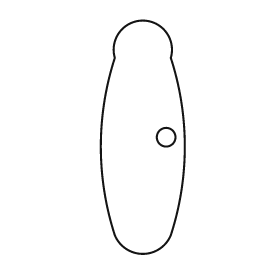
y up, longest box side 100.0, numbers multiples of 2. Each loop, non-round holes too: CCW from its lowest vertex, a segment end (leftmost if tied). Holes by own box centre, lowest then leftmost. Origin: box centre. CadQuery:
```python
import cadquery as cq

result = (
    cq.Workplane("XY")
    .moveTo(-12.0, -42.0)
    .threePointArc((0.0, -50.0), (12.0, -42.0))
    .threePointArc((18.0, -4.0), (12.0, 34.0))
    .threePointArc((0.0, 50.0), (-12.0, 34.0))
    .threePointArc((-18.0, -4.0), (-12.0, -42.0))
    .close()
    .moveTo(10.0, 0.0)
    .circle(4.0)
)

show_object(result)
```